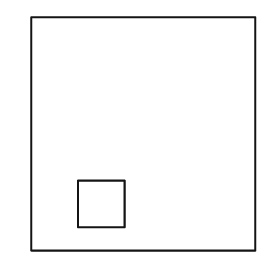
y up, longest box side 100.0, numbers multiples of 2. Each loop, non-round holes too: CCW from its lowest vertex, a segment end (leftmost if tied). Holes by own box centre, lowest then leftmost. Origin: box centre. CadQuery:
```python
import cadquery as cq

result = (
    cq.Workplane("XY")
    .moveTo(-48.0, -50.0)
    .lineTo(48.0, -50.0)
    .lineTo(48.0, 50.0)
    .lineTo(-48.0, 50.0)
    .close()
    .moveTo(-28.0, -40.0)
    .lineTo(-8.0, -40.0)
    .lineTo(-8.0, -20.0)
    .lineTo(-28.0, -20.0)
    .close()
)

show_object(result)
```